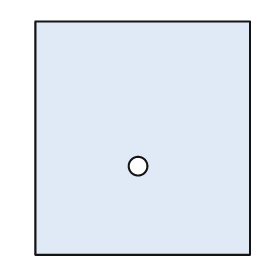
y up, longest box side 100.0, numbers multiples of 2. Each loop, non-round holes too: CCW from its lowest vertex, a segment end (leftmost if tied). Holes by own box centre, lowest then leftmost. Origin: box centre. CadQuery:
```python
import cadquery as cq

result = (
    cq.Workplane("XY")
    .moveTo(-46.0, -50.0)
    .lineTo(46.0, -50.0)
    .lineTo(46.0, 50.0)
    .lineTo(-46.0, 50.0)
    .close()
    .moveTo(-2.0, -12.0)
    .circle(4.0)
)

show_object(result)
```